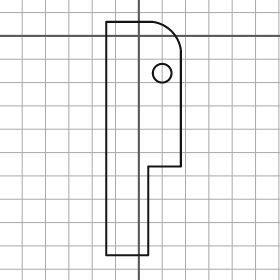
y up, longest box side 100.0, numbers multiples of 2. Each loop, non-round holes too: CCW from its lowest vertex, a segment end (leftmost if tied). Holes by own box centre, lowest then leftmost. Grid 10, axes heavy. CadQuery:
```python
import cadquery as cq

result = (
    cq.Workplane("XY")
    .moveTo(-14.0, -94.0)
    .lineTo(4.0, -94.0)
    .lineTo(4.0, -56.0)
    .lineTo(18.0, -56.0)
    .lineTo(18.0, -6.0)
    .threePointArc((14.0, 2.0), (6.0, 6.0))
    .lineTo(-14.0, 6.0)
    .close()
    .moveTo(10.0, -16.0)
    .circle(4.0)
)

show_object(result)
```